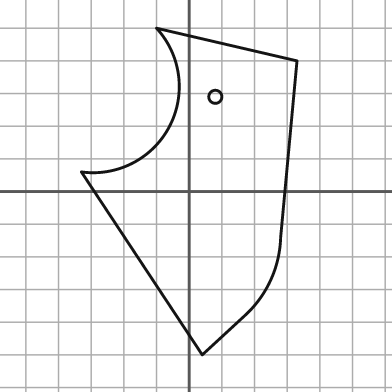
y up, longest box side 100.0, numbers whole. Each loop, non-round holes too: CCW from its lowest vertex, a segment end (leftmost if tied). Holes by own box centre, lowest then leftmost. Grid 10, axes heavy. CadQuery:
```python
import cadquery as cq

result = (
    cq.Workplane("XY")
    .moveTo(4.0, -50.0)
    .lineTo(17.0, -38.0)
    .threePointArc((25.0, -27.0), (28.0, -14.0))
    .lineTo(33.0, 40.0)
    .lineTo(-10.0, 50.0)
    .threePointArc((-6.0, 20.0), (-33.0, 6.0))
    .close()
    .moveTo(8.0, 29.0)
    .circle(2.0)
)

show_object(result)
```